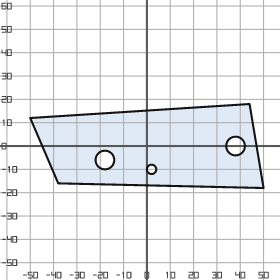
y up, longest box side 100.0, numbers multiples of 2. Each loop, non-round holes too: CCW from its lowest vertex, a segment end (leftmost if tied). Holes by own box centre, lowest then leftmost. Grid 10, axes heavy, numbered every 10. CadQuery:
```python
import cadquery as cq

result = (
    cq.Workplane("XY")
    .moveTo(50.0, -18.0)
    .lineTo(44.0, 18.0)
    .lineTo(-50.0, 12.0)
    .lineTo(-38.0, -16.0)
    .close()
    .moveTo(2.0, -10.0)
    .circle(2.0)
    .moveTo(-18.0, -6.0)
    .circle(4.0)
    .moveTo(38.0, 0.0)
    .circle(4.0)
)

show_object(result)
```